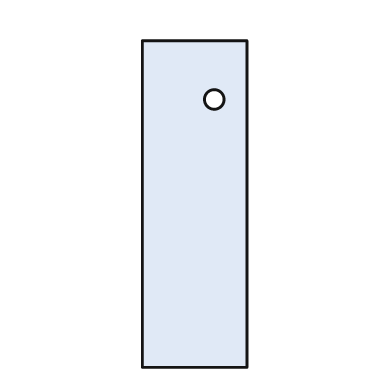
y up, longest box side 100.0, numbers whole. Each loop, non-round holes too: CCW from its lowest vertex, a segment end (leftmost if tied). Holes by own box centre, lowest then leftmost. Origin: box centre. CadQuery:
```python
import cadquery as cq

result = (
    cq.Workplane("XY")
    .moveTo(-16.0, -50.0)
    .lineTo(16.0, -50.0)
    .lineTo(16.0, 50.0)
    .lineTo(-16.0, 50.0)
    .close()
    .moveTo(6.0, 32.0)
    .circle(3.0)
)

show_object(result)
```